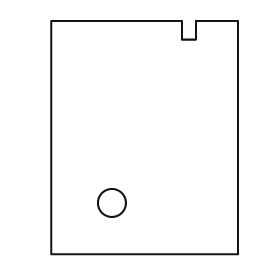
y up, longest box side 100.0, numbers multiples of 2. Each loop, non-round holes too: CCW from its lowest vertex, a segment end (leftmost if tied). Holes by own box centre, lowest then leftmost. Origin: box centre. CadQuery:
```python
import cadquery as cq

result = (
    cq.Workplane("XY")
    .moveTo(-40.0, -50.0)
    .lineTo(40.0, -50.0)
    .lineTo(40.0, 50.0)
    .lineTo(22.0, 50.0)
    .lineTo(22.0, 42.0)
    .lineTo(16.0, 42.0)
    .lineTo(16.0, 50.0)
    .lineTo(-40.0, 50.0)
    .close()
    .moveTo(-14.0, -28.0)
    .circle(6.0)
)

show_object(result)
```